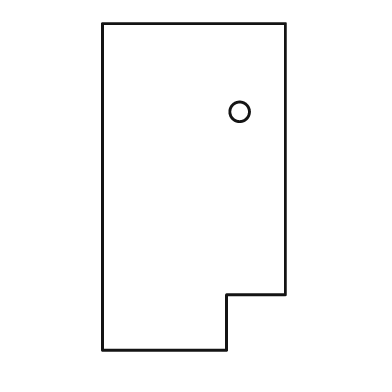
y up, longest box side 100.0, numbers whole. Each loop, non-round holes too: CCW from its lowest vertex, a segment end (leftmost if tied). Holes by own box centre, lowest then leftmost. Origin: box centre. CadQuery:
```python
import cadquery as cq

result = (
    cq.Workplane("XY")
    .moveTo(-28.0, -50.0)
    .lineTo(10.0, -50.0)
    .lineTo(10.0, -33.0)
    .lineTo(28.0, -33.0)
    .lineTo(28.0, 50.0)
    .lineTo(-28.0, 50.0)
    .close()
    .moveTo(14.0, 23.0)
    .circle(3.0)
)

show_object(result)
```